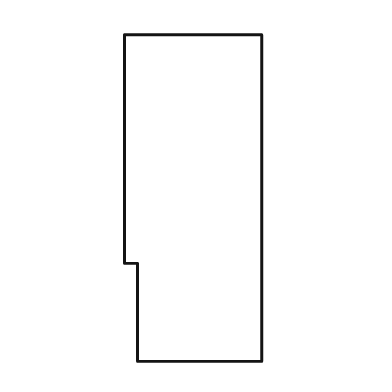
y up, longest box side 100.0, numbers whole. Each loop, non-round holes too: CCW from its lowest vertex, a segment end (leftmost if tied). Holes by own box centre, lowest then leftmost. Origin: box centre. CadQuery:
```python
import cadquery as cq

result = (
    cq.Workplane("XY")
    .moveTo(-17.0, -50.0)
    .lineTo(21.0, -50.0)
    .lineTo(21.0, 50.0)
    .lineTo(-21.0, 50.0)
    .lineTo(-21.0, -20.0)
    .lineTo(-17.0, -20.0)
    .close()
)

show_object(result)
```